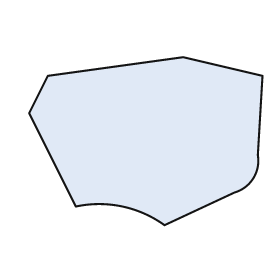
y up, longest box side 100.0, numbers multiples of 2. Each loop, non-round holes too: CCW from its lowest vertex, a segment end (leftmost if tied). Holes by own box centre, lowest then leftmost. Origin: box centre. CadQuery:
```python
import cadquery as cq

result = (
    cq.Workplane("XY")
    .moveTo(8.0, -36.0)
    .lineTo(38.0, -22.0)
    .threePointArc((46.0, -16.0), (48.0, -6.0))
    .lineTo(50.0, 28.0)
    .lineTo(16.0, 36.0)
    .lineTo(-42.0, 28.0)
    .lineTo(-50.0, 12.0)
    .lineTo(-30.0, -28.0)
    .threePointArc((-10.0, -28.0), (8.0, -36.0))
    .close()
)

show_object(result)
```